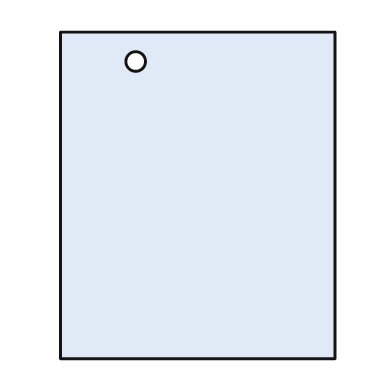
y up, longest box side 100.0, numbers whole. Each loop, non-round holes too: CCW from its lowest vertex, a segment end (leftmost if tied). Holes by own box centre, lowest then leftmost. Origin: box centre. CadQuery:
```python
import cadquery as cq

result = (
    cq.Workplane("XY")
    .moveTo(-42.0, -50.0)
    .lineTo(42.0, -50.0)
    .lineTo(42.0, 50.0)
    .lineTo(-42.0, 50.0)
    .close()
    .moveTo(-19.0, 41.0)
    .circle(3.0)
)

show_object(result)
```